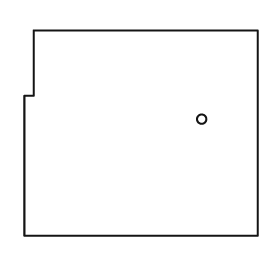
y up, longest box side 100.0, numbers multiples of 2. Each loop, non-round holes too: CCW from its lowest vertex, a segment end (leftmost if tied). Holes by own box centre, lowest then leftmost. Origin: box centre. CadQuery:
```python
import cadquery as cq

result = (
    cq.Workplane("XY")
    .moveTo(-50.0, -44.0)
    .lineTo(50.0, -44.0)
    .lineTo(50.0, 44.0)
    .lineTo(-46.0, 44.0)
    .lineTo(-46.0, 16.0)
    .lineTo(-50.0, 16.0)
    .close()
    .moveTo(26.0, 6.0)
    .circle(2.0)
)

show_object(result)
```